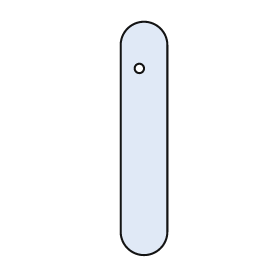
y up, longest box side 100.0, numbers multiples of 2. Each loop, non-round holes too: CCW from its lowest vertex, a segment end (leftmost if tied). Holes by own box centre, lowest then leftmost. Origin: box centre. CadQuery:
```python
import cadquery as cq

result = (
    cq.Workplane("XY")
    .moveTo(-10.0, -40.0)
    .threePointArc((0.0, -50.0), (10.0, -40.0))
    .lineTo(10.0, 40.0)
    .threePointArc((0.0, 50.0), (-10.0, 40.0))
    .close()
    .moveTo(-2.0, 30.0)
    .circle(2.0)
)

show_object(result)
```